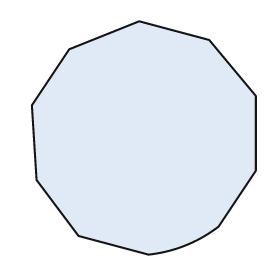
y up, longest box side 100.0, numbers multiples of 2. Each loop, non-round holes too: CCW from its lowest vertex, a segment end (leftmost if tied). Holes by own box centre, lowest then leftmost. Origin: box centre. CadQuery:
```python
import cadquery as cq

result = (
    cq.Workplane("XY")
    .moveTo(2.0, -50.0)
    .threePointArc((18.0, -46.0), (32.0, -38.0))
    .lineTo(48.0, -14.0)
    .lineTo(48.0, 18.0)
    .lineTo(28.0, 42.0)
    .lineTo(-2.0, 50.0)
    .lineTo(-32.0, 38.0)
    .lineTo(-48.0, 14.0)
    .lineTo(-46.0, -18.0)
    .lineTo(-28.0, -42.0)
    .close()
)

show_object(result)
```